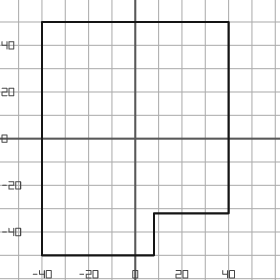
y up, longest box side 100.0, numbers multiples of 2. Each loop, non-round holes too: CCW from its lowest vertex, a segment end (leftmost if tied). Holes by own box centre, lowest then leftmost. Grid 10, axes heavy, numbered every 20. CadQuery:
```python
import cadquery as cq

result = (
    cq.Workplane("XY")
    .moveTo(-40.0, -50.0)
    .lineTo(8.0, -50.0)
    .lineTo(8.0, -32.0)
    .lineTo(40.0, -32.0)
    .lineTo(40.0, 50.0)
    .lineTo(-40.0, 50.0)
    .close()
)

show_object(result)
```